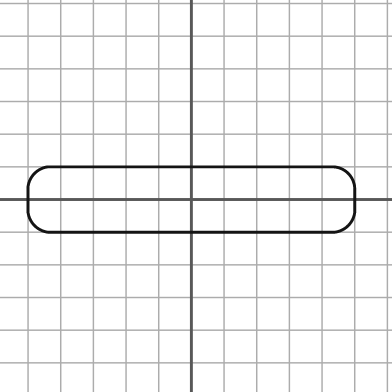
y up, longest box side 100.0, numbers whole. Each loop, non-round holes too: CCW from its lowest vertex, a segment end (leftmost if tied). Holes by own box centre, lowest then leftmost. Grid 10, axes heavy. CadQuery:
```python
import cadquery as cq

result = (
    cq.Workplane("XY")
    .moveTo(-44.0, -10.0)
    .lineTo(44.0, -10.0)
    .threePointArc((48.0, -8.0), (50.0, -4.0))
    .lineTo(50.0, 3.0)
    .threePointArc((48.0, 8.0), (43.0, 10.0))
    .lineTo(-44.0, 10.0)
    .threePointArc((-48.0, 8.0), (-50.0, 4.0))
    .lineTo(-50.0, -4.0)
    .threePointArc((-48.0, -8.0), (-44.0, -10.0))
    .close()
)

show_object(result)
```